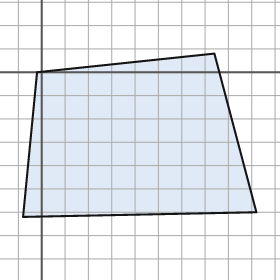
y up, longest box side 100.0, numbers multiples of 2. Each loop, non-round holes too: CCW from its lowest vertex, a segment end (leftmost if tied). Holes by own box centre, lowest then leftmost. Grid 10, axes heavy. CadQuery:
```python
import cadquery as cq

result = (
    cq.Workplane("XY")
    .moveTo(-8.0, -62.0)
    .lineTo(92.0, -60.0)
    .lineTo(74.0, 8.0)
    .lineTo(-2.0, 0.0)
    .close()
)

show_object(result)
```